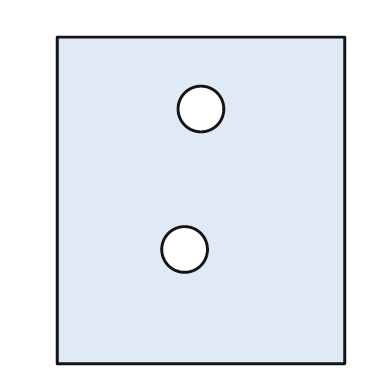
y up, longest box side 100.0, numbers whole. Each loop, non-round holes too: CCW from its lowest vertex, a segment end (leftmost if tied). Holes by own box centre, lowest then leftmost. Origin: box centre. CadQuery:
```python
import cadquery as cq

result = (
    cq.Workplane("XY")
    .moveTo(-44.0, -50.0)
    .lineTo(44.0, -50.0)
    .lineTo(44.0, 50.0)
    .lineTo(-44.0, 50.0)
    .close()
    .moveTo(-5.0, -15.0)
    .circle(7.0)
    .moveTo(0.0, 28.0)
    .circle(7.0)
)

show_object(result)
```